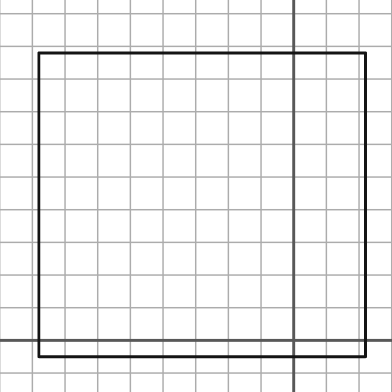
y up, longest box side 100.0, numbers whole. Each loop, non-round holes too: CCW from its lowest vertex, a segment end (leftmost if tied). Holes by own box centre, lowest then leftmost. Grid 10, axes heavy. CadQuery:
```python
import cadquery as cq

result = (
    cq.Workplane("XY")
    .moveTo(-78.0, -5.0)
    .lineTo(22.0, -5.0)
    .lineTo(22.0, 88.0)
    .lineTo(-78.0, 88.0)
    .close()
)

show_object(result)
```